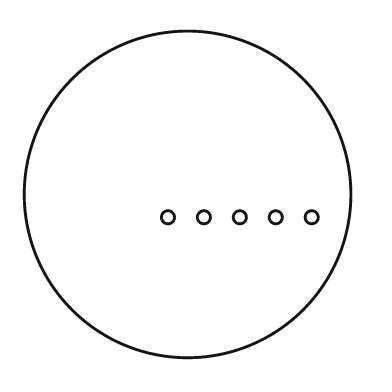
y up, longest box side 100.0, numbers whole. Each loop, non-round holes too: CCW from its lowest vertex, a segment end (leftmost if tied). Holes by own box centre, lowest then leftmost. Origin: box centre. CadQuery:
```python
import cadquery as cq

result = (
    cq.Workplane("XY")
    .moveTo(0.0, 0.0)
    .circle(50.0)
    .moveTo(-6.0, -7.0)
    .circle(2.0)
    .moveTo(5.0, -7.0)
    .circle(2.0)
    .moveTo(16.0, -7.0)
    .circle(2.0)
    .moveTo(27.0, -7.0)
    .circle(2.0)
    .moveTo(38.0, -7.0)
    .circle(2.0)
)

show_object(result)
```